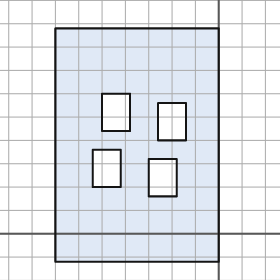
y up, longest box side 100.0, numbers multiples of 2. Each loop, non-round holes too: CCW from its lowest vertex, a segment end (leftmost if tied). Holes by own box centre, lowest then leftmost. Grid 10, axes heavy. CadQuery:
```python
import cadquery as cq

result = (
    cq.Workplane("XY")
    .moveTo(-70.0, -12.0)
    .lineTo(0.0, -12.0)
    .lineTo(0.0, 88.0)
    .lineTo(-70.0, 88.0)
    .close()
    .moveTo(-30.0, 16.0)
    .lineTo(-18.0, 16.0)
    .lineTo(-18.0, 32.0)
    .lineTo(-30.0, 32.0)
    .close()
    .moveTo(-54.0, 20.0)
    .lineTo(-42.0, 20.0)
    .lineTo(-42.0, 36.0)
    .lineTo(-54.0, 36.0)
    .close()
    .moveTo(-26.0, 40.0)
    .lineTo(-14.0, 40.0)
    .lineTo(-14.0, 56.0)
    .lineTo(-26.0, 56.0)
    .close()
    .moveTo(-50.0, 44.0)
    .lineTo(-38.0, 44.0)
    .lineTo(-38.0, 60.0)
    .lineTo(-50.0, 60.0)
    .close()
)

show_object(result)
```